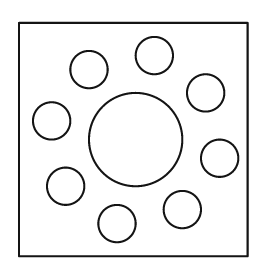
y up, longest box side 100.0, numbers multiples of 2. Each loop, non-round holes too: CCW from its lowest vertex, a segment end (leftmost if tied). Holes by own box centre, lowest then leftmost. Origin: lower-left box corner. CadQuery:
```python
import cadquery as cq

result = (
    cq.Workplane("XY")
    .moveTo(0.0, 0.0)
    .lineTo(98.0, 0.0)
    .lineTo(98.0, 100.0)
    .lineTo(0.0, 100.0)
    .close()
    .moveTo(42.0, 14.0)
    .circle(8.0)
    .moveTo(70.0, 20.0)
    .circle(8.0)
    .moveTo(20.0, 30.0)
    .circle(8.0)
    .moveTo(86.0, 42.0)
    .circle(8.0)
    .moveTo(50.0, 50.0)
    .circle(20.0)
    .moveTo(14.0, 58.0)
    .circle(8.0)
    .moveTo(80.0, 70.0)
    .circle(8.0)
    .moveTo(30.0, 80.0)
    .circle(8.0)
    .moveTo(58.0, 86.0)
    .circle(8.0)
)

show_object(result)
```